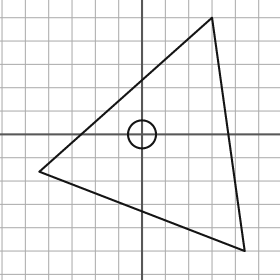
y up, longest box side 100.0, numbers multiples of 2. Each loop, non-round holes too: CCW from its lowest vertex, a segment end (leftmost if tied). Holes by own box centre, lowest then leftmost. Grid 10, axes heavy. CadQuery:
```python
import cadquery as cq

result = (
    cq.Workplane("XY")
    .moveTo(44.0, -50.0)
    .lineTo(30.0, 50.0)
    .lineTo(-44.0, -16.0)
    .close()
    .moveTo(0.0, 0.0)
    .circle(6.0)
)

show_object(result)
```